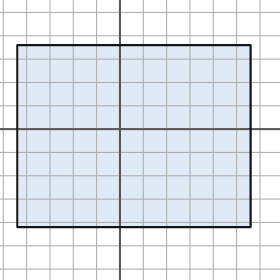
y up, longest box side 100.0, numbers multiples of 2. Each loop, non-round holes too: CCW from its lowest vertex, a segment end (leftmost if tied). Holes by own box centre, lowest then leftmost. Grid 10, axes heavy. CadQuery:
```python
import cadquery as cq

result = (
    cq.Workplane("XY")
    .moveTo(-44.0, -42.0)
    .lineTo(56.0, -42.0)
    .lineTo(56.0, 36.0)
    .lineTo(-44.0, 36.0)
    .close()
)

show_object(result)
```